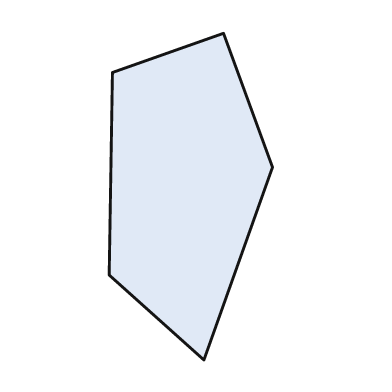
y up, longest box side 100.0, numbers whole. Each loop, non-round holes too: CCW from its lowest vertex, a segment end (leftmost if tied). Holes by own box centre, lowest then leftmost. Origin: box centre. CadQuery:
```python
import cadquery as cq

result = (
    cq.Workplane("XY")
    .moveTo(4.0, -50.0)
    .lineTo(25.0, 9.0)
    .lineTo(10.0, 50.0)
    .lineTo(-24.0, 38.0)
    .lineTo(-25.0, -24.0)
    .close()
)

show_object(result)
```